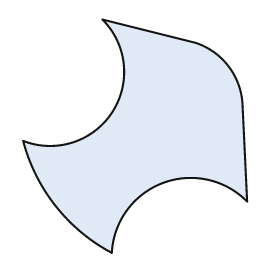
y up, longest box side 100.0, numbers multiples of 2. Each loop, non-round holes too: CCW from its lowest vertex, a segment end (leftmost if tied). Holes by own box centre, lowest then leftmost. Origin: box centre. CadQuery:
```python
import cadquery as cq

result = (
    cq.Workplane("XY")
    .moveTo(-10.0, -50.0)
    .threePointArc((12.0, -20.0), (48.0, -28.0))
    .lineTo(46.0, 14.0)
    .threePointArc((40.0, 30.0), (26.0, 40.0))
    .lineTo(-14.0, 50.0)
    .threePointArc((-10.0, 10.0), (-48.0, -2.0))
    .threePointArc((-34.0, -30.0), (-10.0, -50.0))
    .close()
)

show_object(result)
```